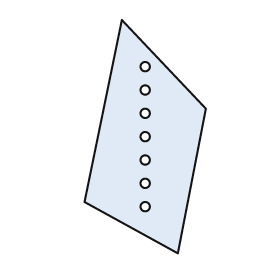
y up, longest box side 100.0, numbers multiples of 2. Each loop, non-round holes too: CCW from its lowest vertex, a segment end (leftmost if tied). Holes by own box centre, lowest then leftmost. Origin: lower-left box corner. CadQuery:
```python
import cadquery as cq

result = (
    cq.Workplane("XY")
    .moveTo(40.0, 0.0)
    .lineTo(52.0, 62.0)
    .lineTo(16.0, 100.0)
    .lineTo(0.0, 22.0)
    .close()
    .moveTo(26.0, 20.0)
    .circle(2.0)
    .moveTo(26.0, 30.0)
    .circle(2.0)
    .moveTo(26.0, 40.0)
    .circle(2.0)
    .moveTo(26.0, 50.0)
    .circle(2.0)
    .moveTo(26.0, 60.0)
    .circle(2.0)
    .moveTo(26.0, 70.0)
    .circle(2.0)
    .moveTo(26.0, 80.0)
    .circle(2.0)
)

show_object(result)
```